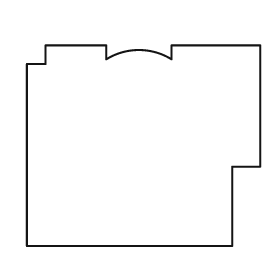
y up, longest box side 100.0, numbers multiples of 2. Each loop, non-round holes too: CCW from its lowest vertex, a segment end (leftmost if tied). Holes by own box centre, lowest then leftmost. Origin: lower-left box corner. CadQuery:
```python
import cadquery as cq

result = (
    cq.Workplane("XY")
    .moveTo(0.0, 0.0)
    .lineTo(88.0, 0.0)
    .lineTo(88.0, 34.0)
    .lineTo(100.0, 34.0)
    .lineTo(100.0, 86.0)
    .lineTo(62.0, 86.0)
    .lineTo(62.0, 80.0)
    .threePointArc((48.0, 84.0), (34.0, 80.0))
    .lineTo(34.0, 86.0)
    .lineTo(8.0, 86.0)
    .lineTo(8.0, 78.0)
    .lineTo(0.0, 78.0)
    .close()
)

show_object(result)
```